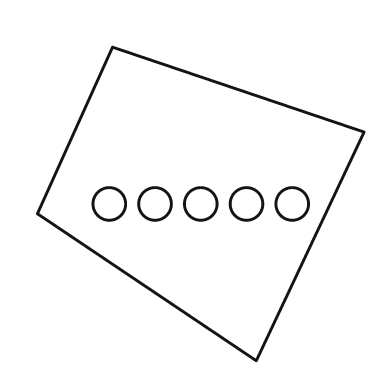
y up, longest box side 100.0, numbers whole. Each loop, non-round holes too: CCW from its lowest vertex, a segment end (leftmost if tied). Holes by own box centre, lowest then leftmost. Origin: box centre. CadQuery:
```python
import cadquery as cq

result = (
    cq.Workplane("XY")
    .moveTo(17.0, -48.0)
    .lineTo(50.0, 22.0)
    .lineTo(-27.0, 48.0)
    .lineTo(-50.0, -3.0)
    .close()
    .moveTo(-28.0, 0.0)
    .circle(5.0)
    .moveTo(-14.0, 0.0)
    .circle(5.0)
    .moveTo(0.0, 0.0)
    .circle(5.0)
    .moveTo(14.0, 0.0)
    .circle(5.0)
    .moveTo(28.0, 0.0)
    .circle(5.0)
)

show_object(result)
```